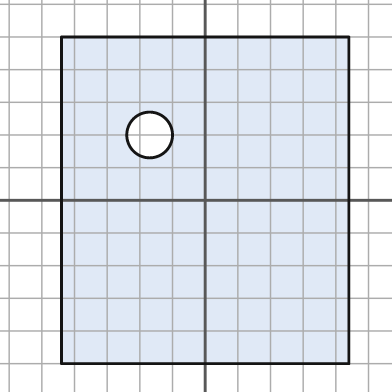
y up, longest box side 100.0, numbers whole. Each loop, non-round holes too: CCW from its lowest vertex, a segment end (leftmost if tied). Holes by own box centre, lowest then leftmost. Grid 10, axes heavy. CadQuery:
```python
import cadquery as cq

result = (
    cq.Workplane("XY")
    .moveTo(-44.0, -50.0)
    .lineTo(44.0, -50.0)
    .lineTo(44.0, 50.0)
    .lineTo(-44.0, 50.0)
    .close()
    .moveTo(-17.0, 20.0)
    .circle(7.0)
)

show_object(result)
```